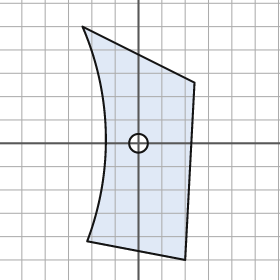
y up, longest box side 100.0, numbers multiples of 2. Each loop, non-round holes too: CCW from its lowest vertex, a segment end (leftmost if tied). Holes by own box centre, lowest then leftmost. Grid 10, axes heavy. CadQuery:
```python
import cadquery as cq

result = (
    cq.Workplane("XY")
    .moveTo(20.0, -50.0)
    .lineTo(24.0, 26.0)
    .lineTo(-24.0, 50.0)
    .threePointArc((-14.0, 4.0), (-22.0, -42.0))
    .close()
    .moveTo(0.0, 0.0)
    .circle(4.0)
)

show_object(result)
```